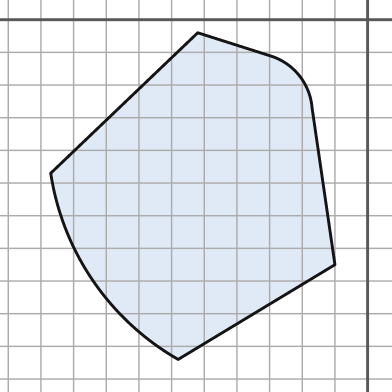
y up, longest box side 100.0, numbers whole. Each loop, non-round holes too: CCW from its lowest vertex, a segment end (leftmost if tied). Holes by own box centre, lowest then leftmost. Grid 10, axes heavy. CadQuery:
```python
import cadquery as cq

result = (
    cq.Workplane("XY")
    .moveTo(-58.0, -104.0)
    .lineTo(-10.0, -75.0)
    .lineTo(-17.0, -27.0)
    .threePointArc((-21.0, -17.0), (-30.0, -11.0))
    .lineTo(-52.0, -4.0)
    .lineTo(-97.0, -47.0)
    .threePointArc((-84.0, -80.0), (-58.0, -104.0))
    .close()
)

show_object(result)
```